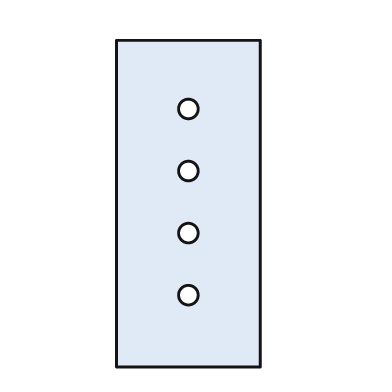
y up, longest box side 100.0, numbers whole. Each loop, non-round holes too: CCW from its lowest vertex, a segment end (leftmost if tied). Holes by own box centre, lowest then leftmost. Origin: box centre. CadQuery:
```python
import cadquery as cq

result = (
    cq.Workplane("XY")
    .moveTo(-22.0, -50.0)
    .lineTo(22.0, -50.0)
    .lineTo(22.0, 50.0)
    .lineTo(-22.0, 50.0)
    .close()
    .moveTo(0.0, -28.0)
    .circle(3.0)
    .moveTo(0.0, -9.0)
    .circle(3.0)
    .moveTo(0.0, 10.0)
    .circle(3.0)
    .moveTo(0.0, 29.0)
    .circle(3.0)
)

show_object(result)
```